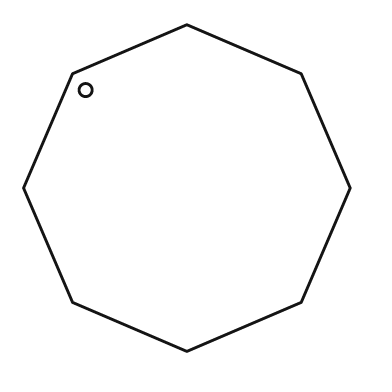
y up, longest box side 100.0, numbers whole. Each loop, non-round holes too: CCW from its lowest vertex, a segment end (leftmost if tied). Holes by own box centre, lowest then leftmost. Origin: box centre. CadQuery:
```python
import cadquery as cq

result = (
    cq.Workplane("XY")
    .moveTo(0.0, -50.0)
    .lineTo(35.0, -35.0)
    .lineTo(50.0, 0.0)
    .lineTo(35.0, 35.0)
    .lineTo(0.0, 50.0)
    .lineTo(-35.0, 35.0)
    .lineTo(-50.0, 0.0)
    .lineTo(-35.0, -35.0)
    .close()
    .moveTo(-31.0, 30.0)
    .circle(2.0)
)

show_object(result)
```